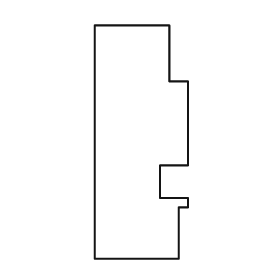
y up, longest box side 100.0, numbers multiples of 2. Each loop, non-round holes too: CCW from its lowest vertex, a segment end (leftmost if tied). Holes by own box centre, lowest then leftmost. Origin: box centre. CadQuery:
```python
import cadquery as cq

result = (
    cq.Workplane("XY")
    .moveTo(-20.0, -50.0)
    .lineTo(16.0, -50.0)
    .lineTo(16.0, -28.0)
    .lineTo(20.0, -28.0)
    .lineTo(20.0, -24.0)
    .lineTo(8.0, -24.0)
    .lineTo(8.0, -10.0)
    .lineTo(20.0, -10.0)
    .lineTo(20.0, 26.0)
    .lineTo(12.0, 26.0)
    .lineTo(12.0, 50.0)
    .lineTo(-20.0, 50.0)
    .close()
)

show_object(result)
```